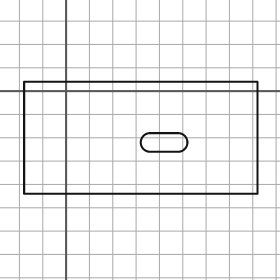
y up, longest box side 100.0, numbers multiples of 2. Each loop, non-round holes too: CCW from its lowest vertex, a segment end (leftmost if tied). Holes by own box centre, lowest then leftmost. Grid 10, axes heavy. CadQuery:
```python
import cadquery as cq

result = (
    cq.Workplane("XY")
    .moveTo(-18.0, -44.0)
    .lineTo(82.0, -44.0)
    .lineTo(82.0, 4.0)
    .lineTo(-18.0, 4.0)
    .close()
    .moveTo(36.0, -26.0)
    .lineTo(48.0, -26.0)
    .threePointArc((52.0, -22.0), (48.0, -18.0))
    .lineTo(36.0, -18.0)
    .threePointArc((32.0, -22.0), (36.0, -26.0))
    .close()
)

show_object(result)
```